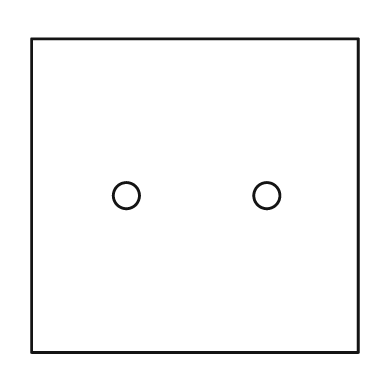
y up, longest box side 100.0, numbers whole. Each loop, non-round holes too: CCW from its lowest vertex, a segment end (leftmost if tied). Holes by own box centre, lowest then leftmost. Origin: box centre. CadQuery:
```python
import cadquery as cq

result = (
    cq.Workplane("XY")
    .moveTo(-50.0, -48.0)
    .lineTo(50.0, -48.0)
    .lineTo(50.0, 48.0)
    .lineTo(-50.0, 48.0)
    .close()
    .moveTo(-21.0, 0.0)
    .circle(4.0)
    .moveTo(22.0, 0.0)
    .circle(4.0)
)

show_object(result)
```